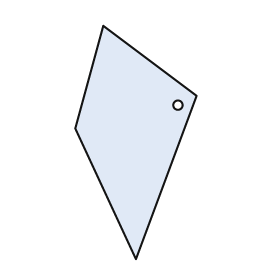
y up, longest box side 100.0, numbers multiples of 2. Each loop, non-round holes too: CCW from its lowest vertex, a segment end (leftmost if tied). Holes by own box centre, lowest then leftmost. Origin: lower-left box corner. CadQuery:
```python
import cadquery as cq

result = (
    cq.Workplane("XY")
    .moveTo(26.0, 0.0)
    .lineTo(52.0, 70.0)
    .lineTo(12.0, 100.0)
    .lineTo(0.0, 56.0)
    .close()
    .moveTo(44.0, 66.0)
    .circle(2.0)
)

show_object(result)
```